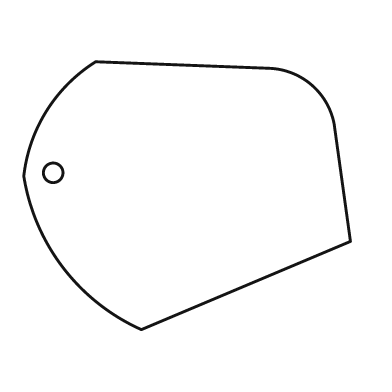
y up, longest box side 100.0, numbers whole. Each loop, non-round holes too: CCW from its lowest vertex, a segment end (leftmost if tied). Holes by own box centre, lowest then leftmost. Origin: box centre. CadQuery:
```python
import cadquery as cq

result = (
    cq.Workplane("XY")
    .moveTo(-14.0, -41.0)
    .lineTo(50.0, -14.0)
    .lineTo(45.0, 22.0)
    .threePointArc((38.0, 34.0), (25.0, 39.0))
    .lineTo(-28.0, 41.0)
    .threePointArc((-43.0, 26.0), (-50.0, 6.0))
    .threePointArc((-38.0, -22.0), (-14.0, -41.0))
    .close()
    .moveTo(-41.0, 7.0)
    .circle(3.0)
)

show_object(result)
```